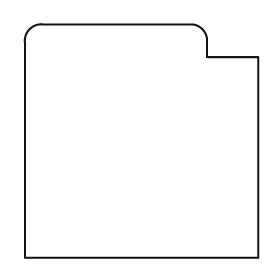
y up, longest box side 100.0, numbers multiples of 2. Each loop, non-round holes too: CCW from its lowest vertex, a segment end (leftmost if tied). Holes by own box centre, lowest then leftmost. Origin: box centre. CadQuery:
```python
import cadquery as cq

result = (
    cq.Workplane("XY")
    .moveTo(-50.0, -50.0)
    .lineTo(50.0, -50.0)
    .lineTo(50.0, 36.0)
    .lineTo(28.0, 36.0)
    .lineTo(28.0, 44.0)
    .threePointArc((26.0, 48.0), (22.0, 50.0))
    .lineTo(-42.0, 50.0)
    .threePointArc((-48.0, 48.0), (-50.0, 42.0))
    .close()
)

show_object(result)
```